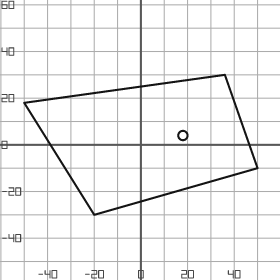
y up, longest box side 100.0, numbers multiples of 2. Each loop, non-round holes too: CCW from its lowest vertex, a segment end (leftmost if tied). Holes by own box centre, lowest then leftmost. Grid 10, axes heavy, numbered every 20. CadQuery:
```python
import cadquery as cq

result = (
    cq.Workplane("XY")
    .moveTo(-20.0, -30.0)
    .lineTo(50.0, -10.0)
    .lineTo(36.0, 30.0)
    .lineTo(-50.0, 18.0)
    .close()
    .moveTo(18.0, 4.0)
    .circle(2.0)
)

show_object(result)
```